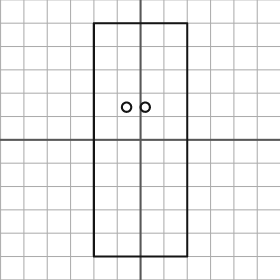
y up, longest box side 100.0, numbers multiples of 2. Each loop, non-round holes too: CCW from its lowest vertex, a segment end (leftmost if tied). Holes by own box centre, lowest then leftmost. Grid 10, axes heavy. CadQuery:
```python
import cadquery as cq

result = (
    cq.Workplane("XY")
    .moveTo(-20.0, -50.0)
    .lineTo(20.0, -50.0)
    .lineTo(20.0, 50.0)
    .lineTo(-20.0, 50.0)
    .close()
    .moveTo(-6.0, 14.0)
    .circle(2.0)
    .moveTo(2.0, 14.0)
    .circle(2.0)
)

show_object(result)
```